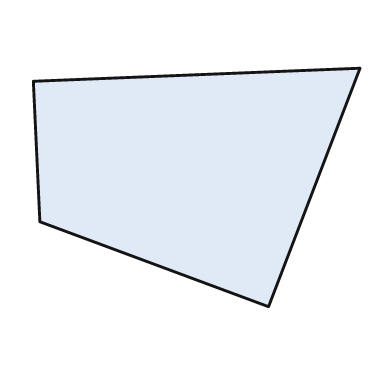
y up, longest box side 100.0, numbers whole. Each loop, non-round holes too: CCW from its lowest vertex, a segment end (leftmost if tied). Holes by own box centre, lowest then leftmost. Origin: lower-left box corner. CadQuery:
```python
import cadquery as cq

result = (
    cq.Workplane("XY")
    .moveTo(72.0, 0.0)
    .lineTo(100.0, 73.0)
    .lineTo(0.0, 69.0)
    .lineTo(2.0, 26.0)
    .close()
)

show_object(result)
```